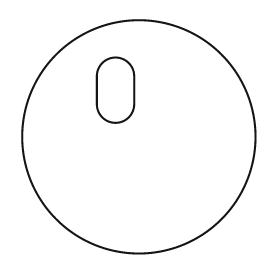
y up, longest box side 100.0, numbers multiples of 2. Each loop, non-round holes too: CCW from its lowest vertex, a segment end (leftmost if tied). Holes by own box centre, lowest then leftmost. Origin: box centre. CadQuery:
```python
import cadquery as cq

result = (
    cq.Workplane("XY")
    .moveTo(0.0, 0.0)
    .circle(50.0)
    .moveTo(-18.0, 14.0)
    .threePointArc((-10.0, 6.0), (-2.0, 14.0))
    .lineTo(-2.0, 26.0)
    .threePointArc((-10.0, 34.0), (-18.0, 26.0))
    .close()
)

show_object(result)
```